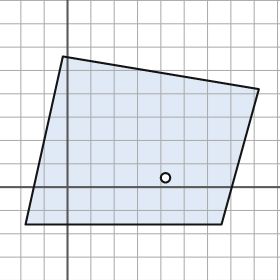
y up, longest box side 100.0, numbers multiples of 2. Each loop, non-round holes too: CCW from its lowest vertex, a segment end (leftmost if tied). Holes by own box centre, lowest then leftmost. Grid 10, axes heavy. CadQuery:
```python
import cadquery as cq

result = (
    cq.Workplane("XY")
    .moveTo(-18.0, -16.0)
    .lineTo(66.0, -16.0)
    .lineTo(82.0, 42.0)
    .lineTo(-2.0, 56.0)
    .close()
    .moveTo(42.0, 4.0)
    .circle(2.0)
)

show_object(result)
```